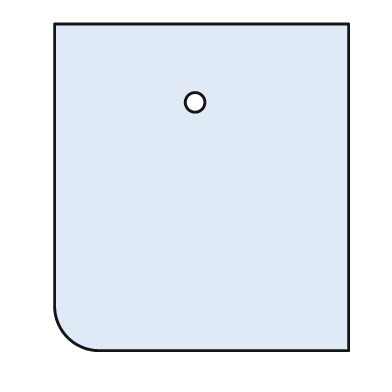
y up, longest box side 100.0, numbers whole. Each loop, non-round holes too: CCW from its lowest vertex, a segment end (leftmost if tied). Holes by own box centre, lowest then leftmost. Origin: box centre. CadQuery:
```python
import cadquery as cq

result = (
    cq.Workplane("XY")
    .moveTo(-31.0, -50.0)
    .lineTo(45.0, -50.0)
    .lineTo(45.0, 50.0)
    .lineTo(-45.0, 50.0)
    .lineTo(-45.0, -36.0)
    .threePointArc((-41.0, -46.0), (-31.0, -50.0))
    .close()
    .moveTo(-2.0, 26.0)
    .circle(3.0)
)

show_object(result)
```